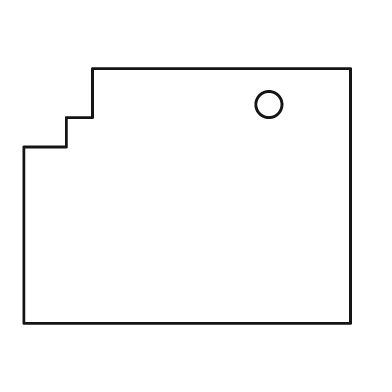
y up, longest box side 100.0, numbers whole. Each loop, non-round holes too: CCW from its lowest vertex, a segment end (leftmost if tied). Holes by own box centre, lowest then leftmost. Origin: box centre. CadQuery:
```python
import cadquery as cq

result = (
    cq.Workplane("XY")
    .moveTo(-50.0, -39.0)
    .lineTo(50.0, -39.0)
    .lineTo(50.0, 39.0)
    .lineTo(-29.0, 39.0)
    .lineTo(-29.0, 24.0)
    .lineTo(-37.0, 24.0)
    .lineTo(-37.0, 15.0)
    .lineTo(-50.0, 15.0)
    .close()
    .moveTo(25.0, 28.0)
    .circle(4.0)
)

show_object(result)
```